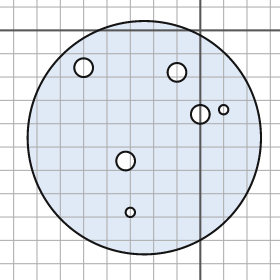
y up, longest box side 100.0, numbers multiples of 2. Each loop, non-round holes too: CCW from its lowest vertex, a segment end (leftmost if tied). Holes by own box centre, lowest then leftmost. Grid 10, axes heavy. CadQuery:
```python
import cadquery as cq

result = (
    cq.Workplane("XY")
    .moveTo(-24.0, -46.0)
    .circle(50.0)
    .moveTo(-30.0, -78.0)
    .circle(2.0)
    .moveTo(-32.0, -56.0)
    .circle(4.0)
    .moveTo(0.0, -36.0)
    .circle(4.0)
    .moveTo(10.0, -34.0)
    .circle(2.0)
    .moveTo(-10.0, -18.0)
    .circle(4.0)
    .moveTo(-50.0, -16.0)
    .circle(4.0)
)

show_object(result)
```